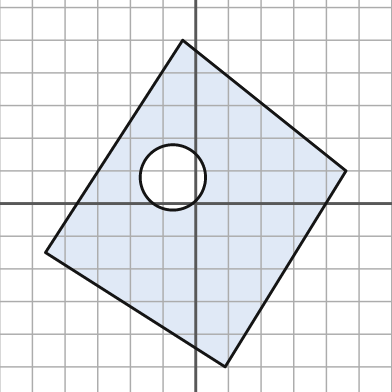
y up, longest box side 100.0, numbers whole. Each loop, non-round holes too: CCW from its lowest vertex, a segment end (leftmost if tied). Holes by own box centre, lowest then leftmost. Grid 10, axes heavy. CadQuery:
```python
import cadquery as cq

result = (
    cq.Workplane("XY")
    .moveTo(9.0, -50.0)
    .lineTo(46.0, 10.0)
    .lineTo(-4.0, 50.0)
    .lineTo(-46.0, -15.0)
    .close()
    .moveTo(-7.0, 8.0)
    .circle(10.0)
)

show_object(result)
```